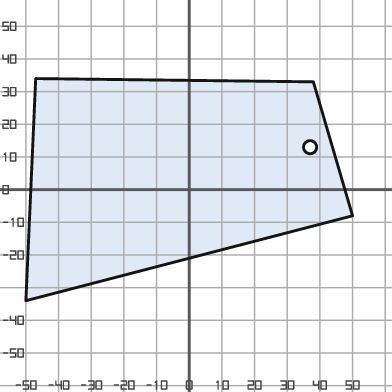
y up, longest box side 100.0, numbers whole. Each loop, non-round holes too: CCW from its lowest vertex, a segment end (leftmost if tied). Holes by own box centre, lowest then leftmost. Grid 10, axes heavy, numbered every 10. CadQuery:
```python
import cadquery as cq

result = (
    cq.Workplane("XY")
    .moveTo(-50.0, -34.0)
    .lineTo(50.0, -8.0)
    .lineTo(38.0, 33.0)
    .lineTo(-47.0, 34.0)
    .close()
    .moveTo(37.0, 13.0)
    .circle(2.0)
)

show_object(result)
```